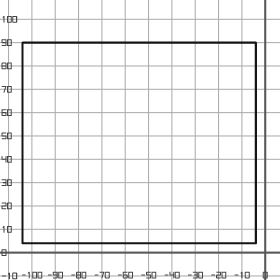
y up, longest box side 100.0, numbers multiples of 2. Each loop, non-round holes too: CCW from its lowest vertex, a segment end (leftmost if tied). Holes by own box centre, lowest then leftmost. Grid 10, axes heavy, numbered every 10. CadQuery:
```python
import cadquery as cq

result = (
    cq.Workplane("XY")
    .moveTo(-104.0, 4.0)
    .lineTo(-4.0, 4.0)
    .lineTo(-4.0, 90.0)
    .lineTo(-104.0, 90.0)
    .close()
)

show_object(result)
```